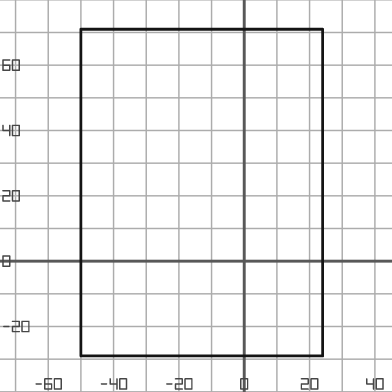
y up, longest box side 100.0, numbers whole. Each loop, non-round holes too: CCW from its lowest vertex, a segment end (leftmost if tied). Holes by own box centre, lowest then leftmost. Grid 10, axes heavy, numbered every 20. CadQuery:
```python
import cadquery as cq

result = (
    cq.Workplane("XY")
    .moveTo(-50.0, -29.0)
    .lineTo(24.0, -29.0)
    .lineTo(24.0, 71.0)
    .lineTo(-50.0, 71.0)
    .close()
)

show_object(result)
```